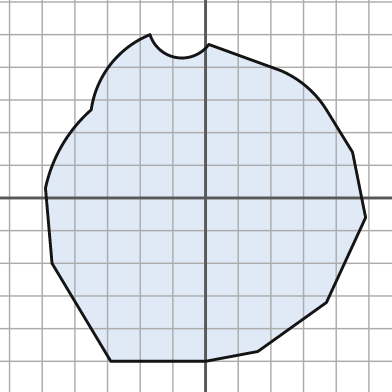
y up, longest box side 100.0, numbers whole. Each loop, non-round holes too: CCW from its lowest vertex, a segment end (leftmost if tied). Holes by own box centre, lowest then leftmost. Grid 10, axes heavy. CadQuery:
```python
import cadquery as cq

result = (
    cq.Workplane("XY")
    .moveTo(-29.0, -50.0)
    .lineTo(0.0, -50.0)
    .lineTo(16.0, -47.0)
    .lineTo(37.0, -32.0)
    .lineTo(49.0, -6.0)
    .lineTo(45.0, 14.0)
    .lineTo(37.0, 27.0)
    .threePointArc((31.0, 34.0), (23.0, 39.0))
    .lineTo(1.0, 47.0)
    .threePointArc((-9.0, 43.0), (-17.0, 50.0))
    .threePointArc((-29.0, 41.0), (-35.0, 27.0))
    .threePointArc((-44.0, 16.0), (-49.0, 3.0))
    .lineTo(-47.0, -20.0)
    .close()
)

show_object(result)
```